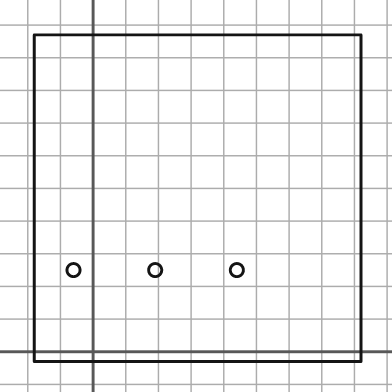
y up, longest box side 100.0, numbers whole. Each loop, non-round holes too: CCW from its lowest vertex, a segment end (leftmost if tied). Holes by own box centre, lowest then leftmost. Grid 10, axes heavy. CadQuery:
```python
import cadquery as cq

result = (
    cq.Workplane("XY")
    .moveTo(-18.0, -3.0)
    .lineTo(82.0, -3.0)
    .lineTo(82.0, 97.0)
    .lineTo(-18.0, 97.0)
    .close()
    .moveTo(-6.0, 25.0)
    .circle(2.0)
    .moveTo(19.0, 25.0)
    .circle(2.0)
    .moveTo(44.0, 25.0)
    .circle(2.0)
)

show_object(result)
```